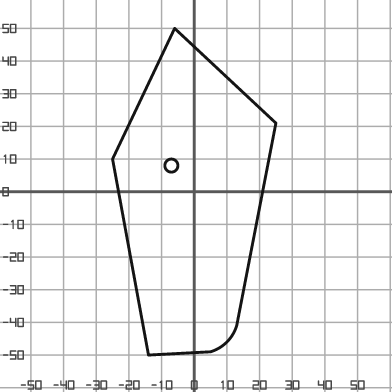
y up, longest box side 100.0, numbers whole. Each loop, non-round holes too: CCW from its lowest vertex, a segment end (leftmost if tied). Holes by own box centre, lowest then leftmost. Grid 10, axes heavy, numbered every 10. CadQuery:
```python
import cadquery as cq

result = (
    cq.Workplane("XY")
    .moveTo(-14.0, -50.0)
    .lineTo(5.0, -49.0)
    .threePointArc((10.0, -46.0), (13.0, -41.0))
    .lineTo(25.0, 21.0)
    .lineTo(-6.0, 50.0)
    .lineTo(-25.0, 10.0)
    .close()
    .moveTo(-7.0, 8.0)
    .circle(2.0)
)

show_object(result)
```